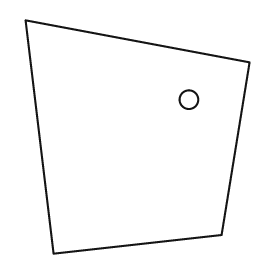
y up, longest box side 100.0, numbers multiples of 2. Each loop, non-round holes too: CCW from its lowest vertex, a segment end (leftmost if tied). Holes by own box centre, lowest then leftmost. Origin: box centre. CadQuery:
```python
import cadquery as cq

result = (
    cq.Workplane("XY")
    .moveTo(-36.0, -50.0)
    .lineTo(36.0, -42.0)
    .lineTo(48.0, 32.0)
    .lineTo(-48.0, 50.0)
    .close()
    .moveTo(22.0, 16.0)
    .circle(4.0)
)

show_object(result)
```